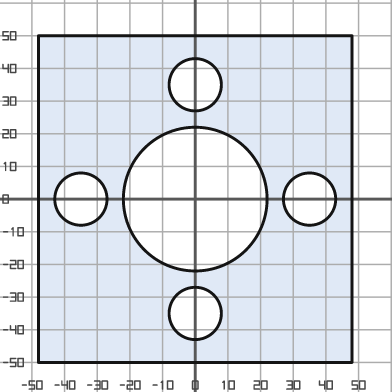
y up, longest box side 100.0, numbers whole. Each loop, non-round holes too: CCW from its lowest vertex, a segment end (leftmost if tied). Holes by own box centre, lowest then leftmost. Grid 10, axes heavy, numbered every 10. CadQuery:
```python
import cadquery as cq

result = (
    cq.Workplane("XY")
    .moveTo(-48.0, -50.0)
    .lineTo(48.0, -50.0)
    .lineTo(48.0, 50.0)
    .lineTo(-48.0, 50.0)
    .close()
    .moveTo(0.0, -35.0)
    .circle(8.0)
    .moveTo(-35.0, 0.0)
    .circle(8.0)
    .moveTo(0.0, 0.0)
    .circle(22.0)
    .moveTo(35.0, 0.0)
    .circle(8.0)
    .moveTo(0.0, 35.0)
    .circle(8.0)
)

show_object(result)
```